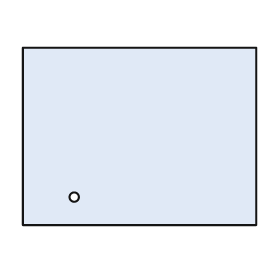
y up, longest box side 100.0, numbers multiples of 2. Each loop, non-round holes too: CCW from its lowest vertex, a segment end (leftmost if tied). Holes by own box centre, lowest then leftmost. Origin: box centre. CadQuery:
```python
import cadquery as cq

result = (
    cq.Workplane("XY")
    .moveTo(-50.0, -38.0)
    .lineTo(50.0, -38.0)
    .lineTo(50.0, 38.0)
    .lineTo(-50.0, 38.0)
    .close()
    .moveTo(-28.0, -26.0)
    .circle(2.0)
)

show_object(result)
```